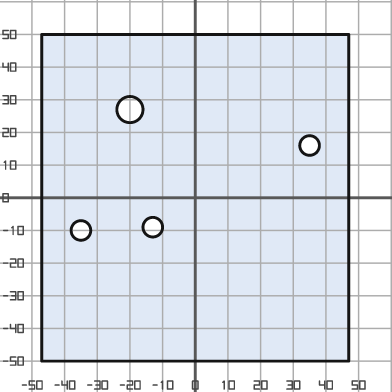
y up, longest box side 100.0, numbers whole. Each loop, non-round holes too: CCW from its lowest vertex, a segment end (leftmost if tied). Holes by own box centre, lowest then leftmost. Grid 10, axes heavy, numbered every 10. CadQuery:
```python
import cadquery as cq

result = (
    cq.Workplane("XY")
    .moveTo(-47.0, -50.0)
    .lineTo(47.0, -50.0)
    .lineTo(47.0, 50.0)
    .lineTo(-47.0, 50.0)
    .close()
    .moveTo(-35.0, -10.0)
    .circle(3.0)
    .moveTo(-13.0, -9.0)
    .circle(3.0)
    .moveTo(35.0, 16.0)
    .circle(3.0)
    .moveTo(-20.0, 27.0)
    .circle(4.0)
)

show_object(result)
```